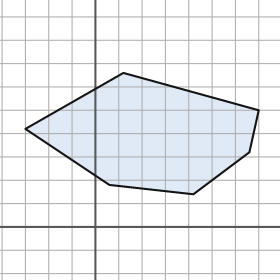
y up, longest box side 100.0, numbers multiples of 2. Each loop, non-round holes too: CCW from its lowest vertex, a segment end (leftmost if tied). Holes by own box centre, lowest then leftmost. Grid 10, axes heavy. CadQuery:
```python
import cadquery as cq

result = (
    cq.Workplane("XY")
    .moveTo(42.0, 14.0)
    .lineTo(66.0, 32.0)
    .lineTo(70.0, 50.0)
    .lineTo(12.0, 66.0)
    .lineTo(-30.0, 42.0)
    .lineTo(6.0, 18.0)
    .close()
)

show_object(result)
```